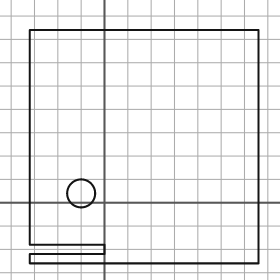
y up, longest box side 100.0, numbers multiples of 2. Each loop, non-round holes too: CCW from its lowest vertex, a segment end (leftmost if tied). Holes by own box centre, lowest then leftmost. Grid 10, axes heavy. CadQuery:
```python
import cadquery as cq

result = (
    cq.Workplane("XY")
    .moveTo(-32.0, -26.0)
    .lineTo(66.0, -26.0)
    .lineTo(66.0, 74.0)
    .lineTo(-32.0, 74.0)
    .lineTo(-32.0, -18.0)
    .lineTo(0.0, -18.0)
    .lineTo(0.0, -22.0)
    .lineTo(-32.0, -22.0)
    .close()
    .moveTo(-10.0, 4.0)
    .circle(6.0)
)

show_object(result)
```